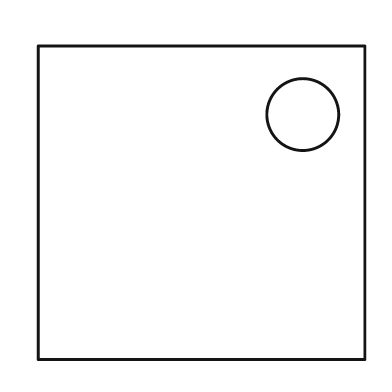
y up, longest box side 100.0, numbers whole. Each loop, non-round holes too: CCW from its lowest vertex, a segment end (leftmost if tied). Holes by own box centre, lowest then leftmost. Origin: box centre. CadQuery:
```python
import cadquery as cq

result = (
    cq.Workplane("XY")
    .moveTo(-50.0, -48.0)
    .lineTo(50.0, -48.0)
    .lineTo(50.0, 48.0)
    .lineTo(-50.0, 48.0)
    .close()
    .moveTo(31.0, 27.0)
    .circle(11.0)
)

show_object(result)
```